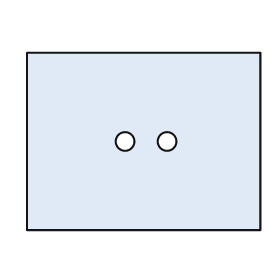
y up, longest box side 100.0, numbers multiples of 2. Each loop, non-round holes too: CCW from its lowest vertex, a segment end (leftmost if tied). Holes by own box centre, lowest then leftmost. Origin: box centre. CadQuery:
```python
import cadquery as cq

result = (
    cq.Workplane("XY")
    .moveTo(-50.0, -38.0)
    .lineTo(50.0, -38.0)
    .lineTo(50.0, 38.0)
    .lineTo(-50.0, 38.0)
    .close()
    .moveTo(-8.0, 0.0)
    .circle(4.0)
    .moveTo(10.0, 0.0)
    .circle(4.0)
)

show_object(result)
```